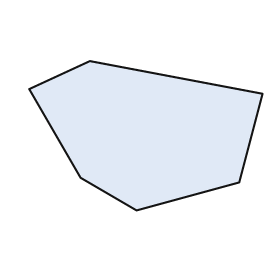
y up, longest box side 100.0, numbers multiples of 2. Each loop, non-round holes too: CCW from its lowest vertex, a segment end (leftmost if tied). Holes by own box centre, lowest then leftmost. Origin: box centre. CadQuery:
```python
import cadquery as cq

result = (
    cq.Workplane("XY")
    .moveTo(-4.0, -32.0)
    .lineTo(40.0, -20.0)
    .lineTo(50.0, 18.0)
    .lineTo(-24.0, 32.0)
    .lineTo(-50.0, 20.0)
    .lineTo(-28.0, -18.0)
    .close()
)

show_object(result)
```